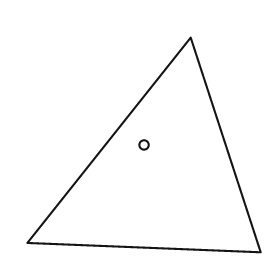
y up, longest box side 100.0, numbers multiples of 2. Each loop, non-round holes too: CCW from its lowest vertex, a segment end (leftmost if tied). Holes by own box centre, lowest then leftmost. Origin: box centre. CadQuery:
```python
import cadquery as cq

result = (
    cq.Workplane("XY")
    .moveTo(50.0, -46.0)
    .lineTo(20.0, 46.0)
    .lineTo(-50.0, -42.0)
    .close()
    .moveTo(0.0, 0.0)
    .circle(2.0)
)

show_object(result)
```